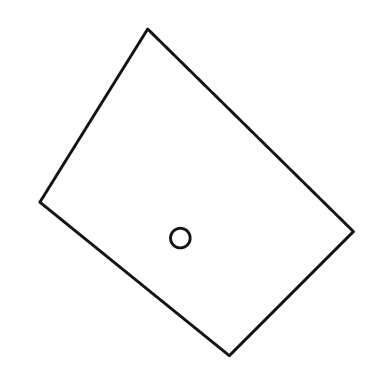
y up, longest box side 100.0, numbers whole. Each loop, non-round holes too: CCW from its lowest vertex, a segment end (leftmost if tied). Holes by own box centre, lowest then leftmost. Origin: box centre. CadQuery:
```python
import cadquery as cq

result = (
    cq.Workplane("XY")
    .moveTo(10.0, -50.0)
    .lineTo(48.0, -12.0)
    .lineTo(-15.0, 50.0)
    .lineTo(-48.0, -3.0)
    .close()
    .moveTo(-5.0, -14.0)
    .circle(3.0)
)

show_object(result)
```